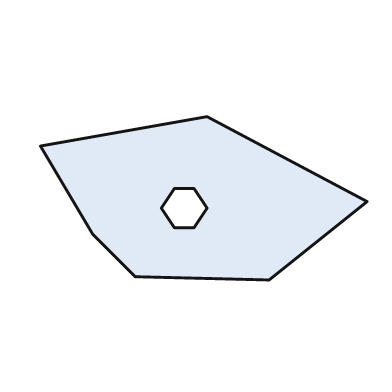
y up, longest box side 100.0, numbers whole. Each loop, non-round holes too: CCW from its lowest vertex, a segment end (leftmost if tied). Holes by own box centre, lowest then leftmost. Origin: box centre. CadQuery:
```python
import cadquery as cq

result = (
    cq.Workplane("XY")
    .moveTo(20.0, -25.0)
    .lineTo(50.0, -1.0)
    .lineTo(1.0, 25.0)
    .lineTo(-50.0, 16.0)
    .lineTo(-34.0, -11.0)
    .lineTo(-21.0, -24.0)
    .close()
    .moveTo(-9.0, -9.0)
    .lineTo(-3.0, -9.0)
    .lineTo(1.0, -3.0)
    .lineTo(-3.0, 3.0)
    .lineTo(-9.0, 3.0)
    .lineTo(-13.0, -3.0)
    .close()
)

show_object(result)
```